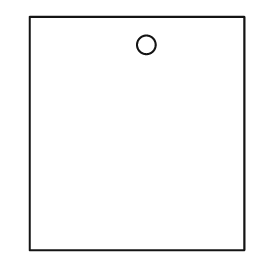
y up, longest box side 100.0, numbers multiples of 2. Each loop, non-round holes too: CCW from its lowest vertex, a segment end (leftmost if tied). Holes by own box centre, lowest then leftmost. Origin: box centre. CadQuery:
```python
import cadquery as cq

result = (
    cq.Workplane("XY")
    .moveTo(-46.0, -50.0)
    .lineTo(46.0, -50.0)
    .lineTo(46.0, 50.0)
    .lineTo(-46.0, 50.0)
    .close()
    .moveTo(4.0, 38.0)
    .circle(4.0)
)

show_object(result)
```